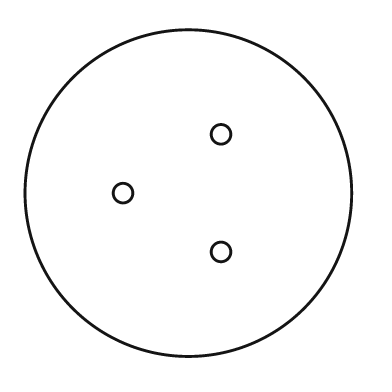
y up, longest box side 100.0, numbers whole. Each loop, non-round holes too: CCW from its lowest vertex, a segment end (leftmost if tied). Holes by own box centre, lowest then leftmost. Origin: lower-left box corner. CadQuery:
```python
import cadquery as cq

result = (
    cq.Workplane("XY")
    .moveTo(50.0, 50.0)
    .circle(50.0)
    .moveTo(60.0, 32.0)
    .circle(3.0)
    .moveTo(30.0, 50.0)
    .circle(3.0)
    .moveTo(60.0, 68.0)
    .circle(3.0)
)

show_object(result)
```